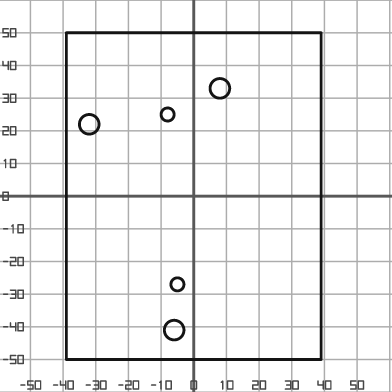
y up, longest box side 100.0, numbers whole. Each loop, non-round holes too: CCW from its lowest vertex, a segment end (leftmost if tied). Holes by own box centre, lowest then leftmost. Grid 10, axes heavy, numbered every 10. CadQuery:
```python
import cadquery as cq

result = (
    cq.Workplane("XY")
    .moveTo(-39.0, -50.0)
    .lineTo(39.0, -50.0)
    .lineTo(39.0, 50.0)
    .lineTo(-39.0, 50.0)
    .close()
    .moveTo(-6.0, -41.0)
    .circle(3.0)
    .moveTo(-5.0, -27.0)
    .circle(2.0)
    .moveTo(-32.0, 22.0)
    .circle(3.0)
    .moveTo(-8.0, 25.0)
    .circle(2.0)
    .moveTo(8.0, 33.0)
    .circle(3.0)
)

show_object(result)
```